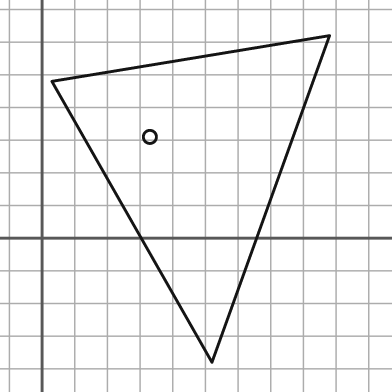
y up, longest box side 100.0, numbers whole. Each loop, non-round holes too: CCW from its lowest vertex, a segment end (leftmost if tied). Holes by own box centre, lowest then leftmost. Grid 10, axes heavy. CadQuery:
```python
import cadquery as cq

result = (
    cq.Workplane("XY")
    .moveTo(52.0, -38.0)
    .lineTo(88.0, 62.0)
    .lineTo(3.0, 48.0)
    .close()
    .moveTo(33.0, 31.0)
    .circle(2.0)
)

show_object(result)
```